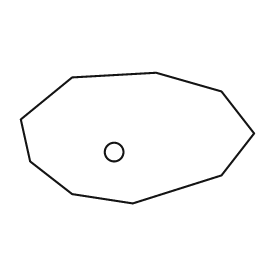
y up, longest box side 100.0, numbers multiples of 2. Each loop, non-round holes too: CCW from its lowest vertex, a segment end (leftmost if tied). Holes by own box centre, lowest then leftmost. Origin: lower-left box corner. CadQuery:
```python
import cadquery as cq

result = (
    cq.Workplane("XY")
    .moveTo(48.0, 0.0)
    .lineTo(86.0, 12.0)
    .lineTo(100.0, 30.0)
    .lineTo(86.0, 48.0)
    .lineTo(58.0, 56.0)
    .lineTo(22.0, 54.0)
    .lineTo(0.0, 36.0)
    .lineTo(4.0, 18.0)
    .lineTo(22.0, 4.0)
    .close()
    .moveTo(40.0, 22.0)
    .circle(4.0)
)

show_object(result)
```